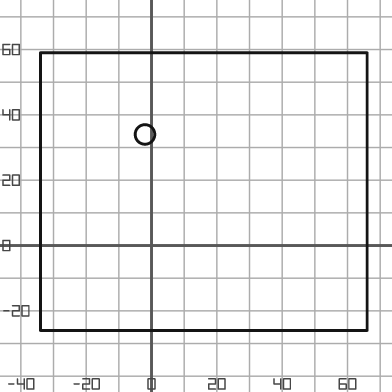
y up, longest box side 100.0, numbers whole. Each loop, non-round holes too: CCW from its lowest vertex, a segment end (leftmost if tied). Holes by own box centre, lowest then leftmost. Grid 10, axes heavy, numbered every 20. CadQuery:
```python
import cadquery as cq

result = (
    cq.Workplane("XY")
    .moveTo(-34.0, -26.0)
    .lineTo(66.0, -26.0)
    .lineTo(66.0, 59.0)
    .lineTo(-34.0, 59.0)
    .close()
    .moveTo(-2.0, 34.0)
    .circle(3.0)
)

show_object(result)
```